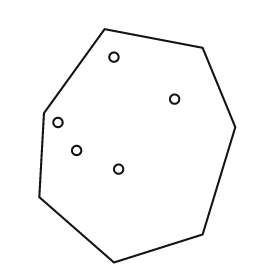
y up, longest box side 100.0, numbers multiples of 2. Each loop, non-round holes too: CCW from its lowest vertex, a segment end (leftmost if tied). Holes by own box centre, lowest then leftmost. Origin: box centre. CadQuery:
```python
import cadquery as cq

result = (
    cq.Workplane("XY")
    .moveTo(-10.0, -50.0)
    .lineTo(28.0, -38.0)
    .lineTo(42.0, 8.0)
    .lineTo(28.0, 42.0)
    .lineTo(-14.0, 50.0)
    .lineTo(-40.0, 14.0)
    .lineTo(-42.0, -22.0)
    .close()
    .moveTo(-8.0, -10.0)
    .circle(2.0)
    .moveTo(-26.0, -2.0)
    .circle(2.0)
    .moveTo(-34.0, 10.0)
    .circle(2.0)
    .moveTo(16.0, 20.0)
    .circle(2.0)
    .moveTo(-10.0, 38.0)
    .circle(2.0)
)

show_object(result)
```